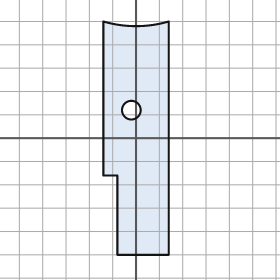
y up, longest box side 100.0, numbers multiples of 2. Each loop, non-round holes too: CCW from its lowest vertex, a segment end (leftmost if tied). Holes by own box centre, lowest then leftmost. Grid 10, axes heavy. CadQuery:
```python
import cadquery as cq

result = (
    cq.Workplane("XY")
    .moveTo(-8.0, -50.0)
    .lineTo(14.0, -50.0)
    .lineTo(14.0, 50.0)
    .threePointArc((0.0, 48.0), (-14.0, 50.0))
    .lineTo(-14.0, -16.0)
    .lineTo(-8.0, -16.0)
    .close()
    .moveTo(-2.0, 12.0)
    .circle(4.0)
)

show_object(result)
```